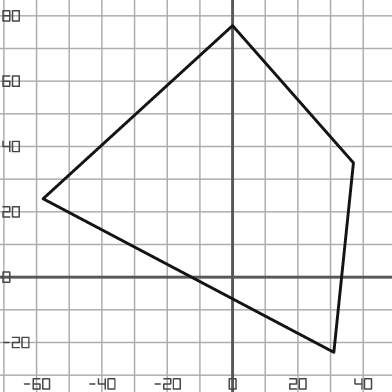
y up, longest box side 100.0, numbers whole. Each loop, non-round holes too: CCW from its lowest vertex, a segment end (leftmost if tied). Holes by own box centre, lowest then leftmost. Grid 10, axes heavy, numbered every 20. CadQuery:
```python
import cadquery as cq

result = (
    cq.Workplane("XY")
    .moveTo(31.0, -23.0)
    .lineTo(37.0, 35.0)
    .lineTo(0.0, 77.0)
    .lineTo(-58.0, 24.0)
    .close()
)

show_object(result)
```